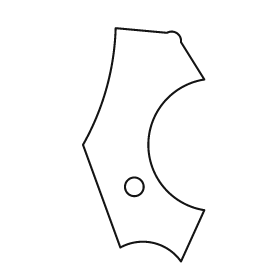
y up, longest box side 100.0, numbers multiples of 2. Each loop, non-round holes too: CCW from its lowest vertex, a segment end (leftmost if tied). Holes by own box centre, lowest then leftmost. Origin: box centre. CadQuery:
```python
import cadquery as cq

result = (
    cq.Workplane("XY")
    .moveTo(16.0, -50.0)
    .lineTo(26.0, -28.0)
    .threePointArc((2.0, 0.0), (26.0, 28.0))
    .lineTo(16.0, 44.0)
    .threePointArc((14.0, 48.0), (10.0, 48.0))
    .lineTo(-12.0, 50.0)
    .threePointArc((-16.0, 24.0), (-26.0, 0.0))
    .lineTo(-10.0, -44.0)
    .threePointArc((4.0, -42.0), (16.0, -50.0))
    .close()
    .moveTo(-4.0, -18.0)
    .circle(4.0)
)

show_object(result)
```